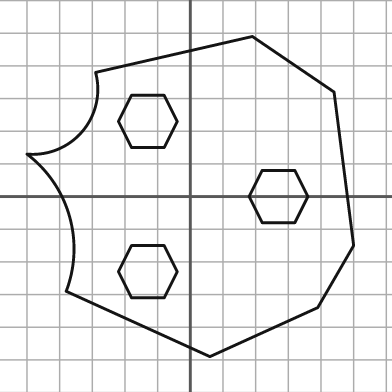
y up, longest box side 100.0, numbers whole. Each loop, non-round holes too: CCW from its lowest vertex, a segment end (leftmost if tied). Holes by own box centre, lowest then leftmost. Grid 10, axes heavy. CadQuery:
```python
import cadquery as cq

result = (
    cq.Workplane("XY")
    .moveTo(6.0, -49.0)
    .lineTo(39.0, -34.0)
    .lineTo(50.0, -15.0)
    .lineTo(44.0, 32.0)
    .lineTo(19.0, 49.0)
    .lineTo(-29.0, 38.0)
    .threePointArc((-33.0, 20.0), (-50.0, 13.0))
    .threePointArc((-37.0, -6.0), (-38.0, -29.0))
    .close()
    .moveTo(-18.0, -31.0)
    .lineTo(-8.0, -31.0)
    .lineTo(-4.0, -23.0)
    .lineTo(-8.0, -15.0)
    .lineTo(-18.0, -15.0)
    .lineTo(-22.0, -23.0)
    .close()
    .moveTo(22.0, -8.0)
    .lineTo(32.0, -8.0)
    .lineTo(36.0, 0.0)
    .lineTo(32.0, 8.0)
    .lineTo(22.0, 8.0)
    .lineTo(18.0, 0.0)
    .close()
    .moveTo(-18.0, 15.0)
    .lineTo(-8.0, 15.0)
    .lineTo(-4.0, 23.0)
    .lineTo(-8.0, 31.0)
    .lineTo(-18.0, 31.0)
    .lineTo(-22.0, 23.0)
    .close()
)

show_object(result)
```